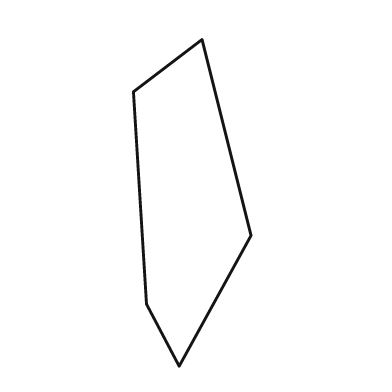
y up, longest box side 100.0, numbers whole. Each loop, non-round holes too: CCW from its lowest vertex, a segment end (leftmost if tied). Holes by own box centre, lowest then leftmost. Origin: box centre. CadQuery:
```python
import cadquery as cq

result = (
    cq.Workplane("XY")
    .moveTo(-4.0, -50.0)
    .lineTo(18.0, -10.0)
    .lineTo(3.0, 50.0)
    .lineTo(-18.0, 34.0)
    .lineTo(-14.0, -31.0)
    .close()
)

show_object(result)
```